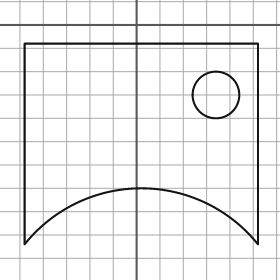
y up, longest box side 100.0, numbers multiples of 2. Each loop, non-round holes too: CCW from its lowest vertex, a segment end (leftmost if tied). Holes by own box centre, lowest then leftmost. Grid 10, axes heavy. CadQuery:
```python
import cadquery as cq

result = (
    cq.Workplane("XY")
    .moveTo(-48.0, -94.0)
    .threePointArc((2.0, -70.0), (52.0, -94.0))
    .lineTo(52.0, -8.0)
    .lineTo(-48.0, -8.0)
    .close()
    .moveTo(34.0, -30.0)
    .circle(10.0)
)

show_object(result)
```